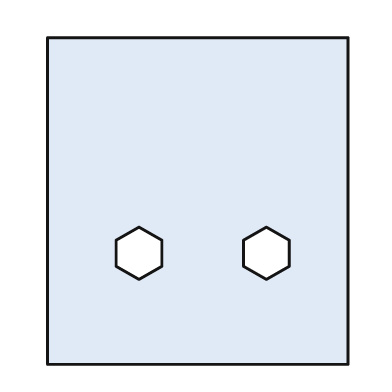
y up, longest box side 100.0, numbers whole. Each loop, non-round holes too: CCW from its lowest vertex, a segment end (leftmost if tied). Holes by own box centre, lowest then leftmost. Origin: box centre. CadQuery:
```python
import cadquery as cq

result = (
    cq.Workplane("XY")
    .moveTo(-46.0, -50.0)
    .lineTo(46.0, -50.0)
    .lineTo(46.0, 50.0)
    .lineTo(-46.0, 50.0)
    .close()
    .moveTo(-18.0, -24.0)
    .lineTo(-11.0, -20.0)
    .lineTo(-11.0, -12.0)
    .lineTo(-18.0, -8.0)
    .lineTo(-25.0, -12.0)
    .lineTo(-25.0, -20.0)
    .close()
    .moveTo(21.0, -24.0)
    .lineTo(28.0, -20.0)
    .lineTo(28.0, -12.0)
    .lineTo(21.0, -8.0)
    .lineTo(14.0, -12.0)
    .lineTo(14.0, -20.0)
    .close()
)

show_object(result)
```